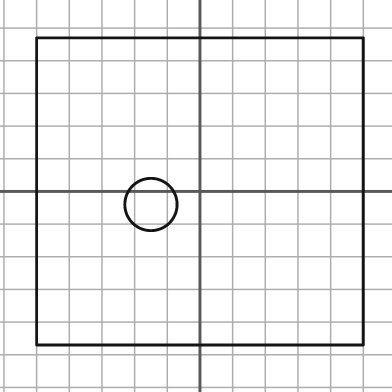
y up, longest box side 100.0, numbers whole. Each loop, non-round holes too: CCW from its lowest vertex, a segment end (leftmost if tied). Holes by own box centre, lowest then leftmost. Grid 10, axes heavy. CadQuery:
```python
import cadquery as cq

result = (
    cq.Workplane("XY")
    .moveTo(-50.0, -47.0)
    .lineTo(50.0, -47.0)
    .lineTo(50.0, 47.0)
    .lineTo(-50.0, 47.0)
    .close()
    .moveTo(-15.0, -4.0)
    .circle(8.0)
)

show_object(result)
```